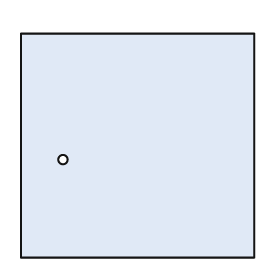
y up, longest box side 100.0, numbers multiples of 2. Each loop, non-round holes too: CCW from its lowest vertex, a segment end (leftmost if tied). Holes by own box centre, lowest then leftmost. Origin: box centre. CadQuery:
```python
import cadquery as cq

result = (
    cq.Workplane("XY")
    .moveTo(-50.0, -48.0)
    .lineTo(50.0, -48.0)
    .lineTo(50.0, 48.0)
    .lineTo(-50.0, 48.0)
    .close()
    .moveTo(-32.0, -6.0)
    .circle(2.0)
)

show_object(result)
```